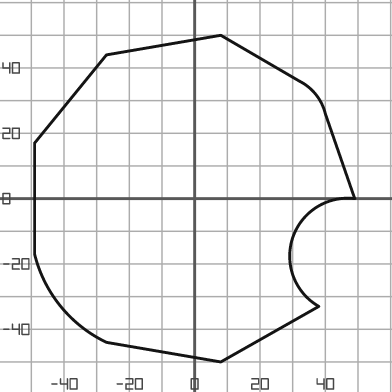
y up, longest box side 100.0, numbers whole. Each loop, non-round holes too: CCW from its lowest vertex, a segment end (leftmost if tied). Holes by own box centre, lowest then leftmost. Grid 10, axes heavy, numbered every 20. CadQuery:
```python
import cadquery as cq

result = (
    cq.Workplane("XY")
    .moveTo(8.0, -50.0)
    .lineTo(38.0, -33.0)
    .threePointArc((30.0, -12.0), (49.0, 0.0))
    .lineTo(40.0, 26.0)
    .threePointArc((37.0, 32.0), (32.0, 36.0))
    .lineTo(8.0, 50.0)
    .lineTo(-27.0, 44.0)
    .lineTo(-49.0, 17.0)
    .lineTo(-49.0, -17.0)
    .threePointArc((-41.0, -33.0), (-27.0, -44.0))
    .close()
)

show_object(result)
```